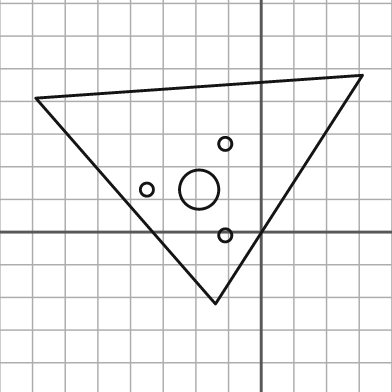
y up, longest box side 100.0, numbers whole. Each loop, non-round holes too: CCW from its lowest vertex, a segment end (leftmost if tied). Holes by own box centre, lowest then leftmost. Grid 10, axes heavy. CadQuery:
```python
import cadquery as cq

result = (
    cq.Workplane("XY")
    .moveTo(-14.0, -22.0)
    .lineTo(31.0, 48.0)
    .lineTo(-69.0, 41.0)
    .close()
    .moveTo(-11.0, -1.0)
    .circle(2.0)
    .moveTo(-35.0, 13.0)
    .circle(2.0)
    .moveTo(-19.0, 13.0)
    .circle(6.0)
    .moveTo(-11.0, 27.0)
    .circle(2.0)
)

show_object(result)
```